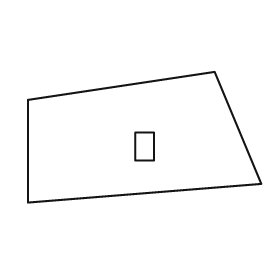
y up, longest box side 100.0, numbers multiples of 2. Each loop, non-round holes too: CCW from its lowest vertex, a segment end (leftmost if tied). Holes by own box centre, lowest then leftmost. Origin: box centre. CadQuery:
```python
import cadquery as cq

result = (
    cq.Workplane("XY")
    .moveTo(-50.0, -28.0)
    .lineTo(50.0, -20.0)
    .lineTo(30.0, 28.0)
    .lineTo(-50.0, 16.0)
    .close()
    .moveTo(-4.0, -10.0)
    .lineTo(4.0, -10.0)
    .lineTo(4.0, 2.0)
    .lineTo(-4.0, 2.0)
    .close()
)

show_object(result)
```